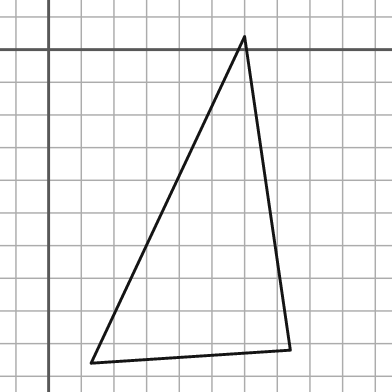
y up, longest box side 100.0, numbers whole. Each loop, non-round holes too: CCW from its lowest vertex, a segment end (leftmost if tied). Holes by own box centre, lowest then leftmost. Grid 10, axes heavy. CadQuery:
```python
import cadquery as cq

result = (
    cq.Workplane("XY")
    .moveTo(13.0, -96.0)
    .lineTo(74.0, -92.0)
    .lineTo(60.0, 4.0)
    .close()
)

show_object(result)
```